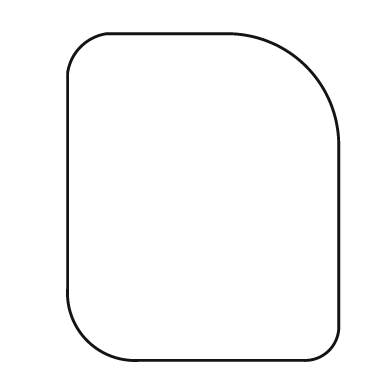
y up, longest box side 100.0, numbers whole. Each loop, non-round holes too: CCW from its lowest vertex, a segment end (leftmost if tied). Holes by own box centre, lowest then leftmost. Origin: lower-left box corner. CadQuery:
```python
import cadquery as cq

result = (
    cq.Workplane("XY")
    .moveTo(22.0, 0.0)
    .lineTo(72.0, 0.0)
    .threePointArc((80.0, 3.0), (83.0, 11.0))
    .lineTo(83.0, 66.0)
    .threePointArc((73.0, 90.0), (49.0, 100.0))
    .lineTo(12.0, 100.0)
    .threePointArc((4.0, 96.0), (0.0, 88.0))
    .lineTo(0.0, 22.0)
    .threePointArc((6.0, 6.0), (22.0, 0.0))
    .close()
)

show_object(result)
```